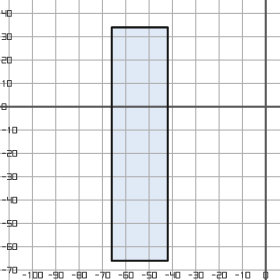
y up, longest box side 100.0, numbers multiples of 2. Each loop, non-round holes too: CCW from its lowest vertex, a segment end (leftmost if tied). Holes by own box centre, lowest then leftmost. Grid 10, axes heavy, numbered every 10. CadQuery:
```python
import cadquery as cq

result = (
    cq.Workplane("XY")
    .moveTo(-66.0, -66.0)
    .lineTo(-42.0, -66.0)
    .lineTo(-42.0, 34.0)
    .lineTo(-66.0, 34.0)
    .close()
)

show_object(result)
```